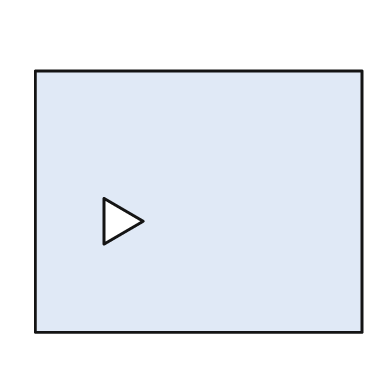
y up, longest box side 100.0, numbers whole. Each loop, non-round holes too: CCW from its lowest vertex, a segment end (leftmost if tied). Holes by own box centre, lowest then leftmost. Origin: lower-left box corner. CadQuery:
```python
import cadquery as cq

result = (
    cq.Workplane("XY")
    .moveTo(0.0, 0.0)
    .lineTo(100.0, 0.0)
    .lineTo(100.0, 80.0)
    .lineTo(0.0, 80.0)
    .close()
    .moveTo(21.0, 27.0)
    .lineTo(33.0, 34.0)
    .lineTo(21.0, 41.0)
    .close()
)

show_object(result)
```